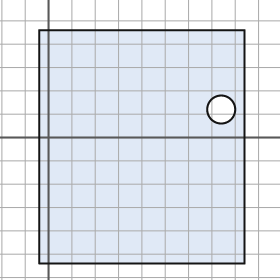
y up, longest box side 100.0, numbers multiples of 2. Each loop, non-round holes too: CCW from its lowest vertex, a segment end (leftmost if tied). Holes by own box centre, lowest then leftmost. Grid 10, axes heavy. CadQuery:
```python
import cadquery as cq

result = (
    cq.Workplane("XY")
    .moveTo(-4.0, -54.0)
    .lineTo(84.0, -54.0)
    .lineTo(84.0, 46.0)
    .lineTo(-4.0, 46.0)
    .close()
    .moveTo(74.0, 12.0)
    .circle(6.0)
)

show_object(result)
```